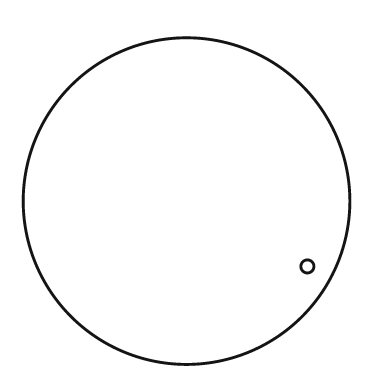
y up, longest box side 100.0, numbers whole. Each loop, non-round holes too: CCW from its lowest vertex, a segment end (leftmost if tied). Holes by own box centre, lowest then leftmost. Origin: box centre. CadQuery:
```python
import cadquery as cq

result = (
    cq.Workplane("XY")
    .moveTo(0.0, 0.0)
    .circle(50.0)
    .moveTo(37.0, -20.0)
    .circle(2.0)
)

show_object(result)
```